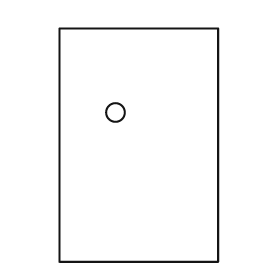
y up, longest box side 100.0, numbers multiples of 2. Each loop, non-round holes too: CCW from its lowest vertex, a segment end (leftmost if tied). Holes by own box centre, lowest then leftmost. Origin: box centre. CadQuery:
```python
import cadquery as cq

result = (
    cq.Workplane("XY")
    .moveTo(-34.0, -50.0)
    .lineTo(34.0, -50.0)
    .lineTo(34.0, 50.0)
    .lineTo(-34.0, 50.0)
    .close()
    .moveTo(-10.0, 14.0)
    .circle(4.0)
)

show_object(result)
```